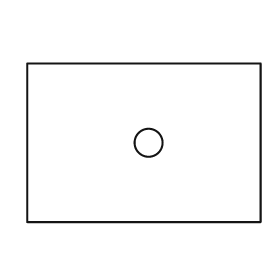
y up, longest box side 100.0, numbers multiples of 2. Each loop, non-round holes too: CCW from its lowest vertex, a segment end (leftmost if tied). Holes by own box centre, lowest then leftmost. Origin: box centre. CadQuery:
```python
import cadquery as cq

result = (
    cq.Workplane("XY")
    .moveTo(-50.0, -34.0)
    .lineTo(50.0, -34.0)
    .lineTo(50.0, 34.0)
    .lineTo(-50.0, 34.0)
    .close()
    .moveTo(2.0, 0.0)
    .circle(6.0)
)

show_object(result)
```